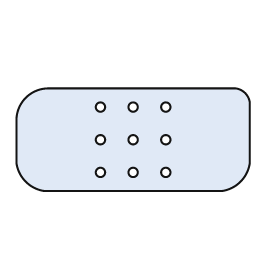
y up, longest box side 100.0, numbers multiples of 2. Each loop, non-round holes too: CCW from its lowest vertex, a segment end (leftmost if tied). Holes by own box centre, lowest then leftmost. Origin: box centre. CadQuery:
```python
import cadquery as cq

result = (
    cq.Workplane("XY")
    .moveTo(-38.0, -22.0)
    .lineTo(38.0, -22.0)
    .threePointArc((46.0, -18.0), (50.0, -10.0))
    .lineTo(50.0, 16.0)
    .threePointArc((48.0, 20.0), (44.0, 22.0))
    .lineTo(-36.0, 22.0)
    .threePointArc((-46.0, 18.0), (-50.0, 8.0))
    .lineTo(-50.0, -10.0)
    .threePointArc((-46.0, -18.0), (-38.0, -22.0))
    .close()
    .moveTo(-14.0, -14.0)
    .circle(2.0)
    .moveTo(0.0, -14.0)
    .circle(2.0)
    .moveTo(14.0, -14.0)
    .circle(2.0)
    .moveTo(-14.0, 0.0)
    .circle(2.0)
    .moveTo(0.0, 0.0)
    .circle(2.0)
    .moveTo(14.0, 0.0)
    .circle(2.0)
    .moveTo(-14.0, 14.0)
    .circle(2.0)
    .moveTo(0.0, 14.0)
    .circle(2.0)
    .moveTo(14.0, 14.0)
    .circle(2.0)
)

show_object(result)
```